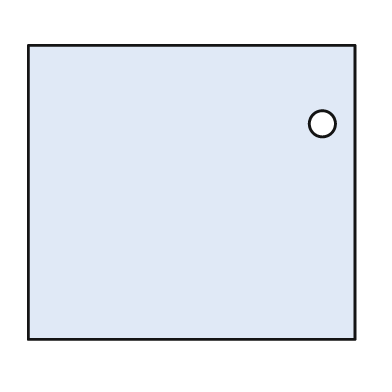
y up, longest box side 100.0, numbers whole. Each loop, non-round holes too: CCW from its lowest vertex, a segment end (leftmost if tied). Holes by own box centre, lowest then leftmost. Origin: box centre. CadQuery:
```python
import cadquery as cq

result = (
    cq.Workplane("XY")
    .moveTo(-50.0, -45.0)
    .lineTo(50.0, -45.0)
    .lineTo(50.0, 45.0)
    .lineTo(-50.0, 45.0)
    .close()
    .moveTo(40.0, 21.0)
    .circle(4.0)
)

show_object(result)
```